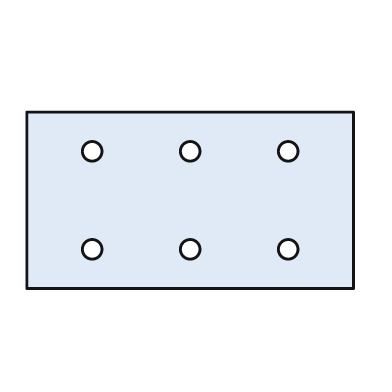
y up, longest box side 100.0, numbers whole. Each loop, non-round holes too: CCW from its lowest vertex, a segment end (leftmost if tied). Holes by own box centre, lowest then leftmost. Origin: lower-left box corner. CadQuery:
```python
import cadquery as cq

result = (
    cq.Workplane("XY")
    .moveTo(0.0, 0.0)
    .lineTo(100.0, 0.0)
    .lineTo(100.0, 54.0)
    .lineTo(0.0, 54.0)
    .close()
    .moveTo(20.0, 12.0)
    .circle(3.0)
    .moveTo(50.0, 12.0)
    .circle(3.0)
    .moveTo(80.0, 12.0)
    .circle(3.0)
    .moveTo(20.0, 42.0)
    .circle(3.0)
    .moveTo(50.0, 42.0)
    .circle(3.0)
    .moveTo(80.0, 42.0)
    .circle(3.0)
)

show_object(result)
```